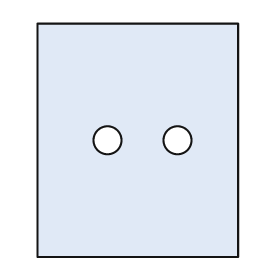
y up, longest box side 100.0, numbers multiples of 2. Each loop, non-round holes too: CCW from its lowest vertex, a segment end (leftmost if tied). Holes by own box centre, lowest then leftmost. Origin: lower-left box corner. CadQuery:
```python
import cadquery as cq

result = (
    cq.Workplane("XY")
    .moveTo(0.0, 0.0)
    .lineTo(86.0, 0.0)
    .lineTo(86.0, 100.0)
    .lineTo(0.0, 100.0)
    .close()
    .moveTo(30.0, 50.0)
    .circle(6.0)
    .moveTo(60.0, 50.0)
    .circle(6.0)
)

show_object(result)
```